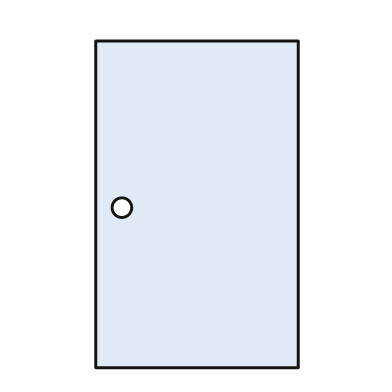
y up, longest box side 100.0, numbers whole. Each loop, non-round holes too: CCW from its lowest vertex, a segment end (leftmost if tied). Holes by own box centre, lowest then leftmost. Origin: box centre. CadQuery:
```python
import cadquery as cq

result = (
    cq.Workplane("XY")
    .moveTo(-31.0, -50.0)
    .lineTo(31.0, -50.0)
    .lineTo(31.0, 50.0)
    .lineTo(-31.0, 50.0)
    .close()
    .moveTo(-23.0, -1.0)
    .circle(3.0)
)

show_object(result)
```